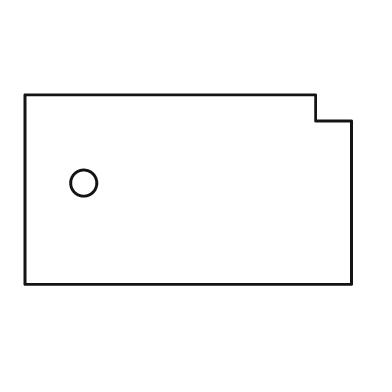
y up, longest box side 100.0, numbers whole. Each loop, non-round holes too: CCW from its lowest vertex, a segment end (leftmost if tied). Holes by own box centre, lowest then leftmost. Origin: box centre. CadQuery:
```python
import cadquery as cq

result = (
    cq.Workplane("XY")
    .moveTo(-50.0, -29.0)
    .lineTo(50.0, -29.0)
    .lineTo(50.0, 21.0)
    .lineTo(39.0, 21.0)
    .lineTo(39.0, 29.0)
    .lineTo(-50.0, 29.0)
    .close()
    .moveTo(-32.0, 2.0)
    .circle(4.0)
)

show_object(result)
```